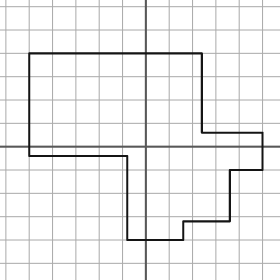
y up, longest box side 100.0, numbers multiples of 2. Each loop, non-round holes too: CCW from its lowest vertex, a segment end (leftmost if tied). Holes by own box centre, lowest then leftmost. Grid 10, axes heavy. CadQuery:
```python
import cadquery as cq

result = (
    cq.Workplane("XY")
    .moveTo(-8.0, -40.0)
    .lineTo(16.0, -40.0)
    .lineTo(16.0, -32.0)
    .lineTo(36.0, -32.0)
    .lineTo(36.0, -10.0)
    .lineTo(50.0, -10.0)
    .lineTo(50.0, 6.0)
    .lineTo(24.0, 6.0)
    .lineTo(24.0, 40.0)
    .lineTo(-50.0, 40.0)
    .lineTo(-50.0, -4.0)
    .lineTo(-8.0, -4.0)
    .close()
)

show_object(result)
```